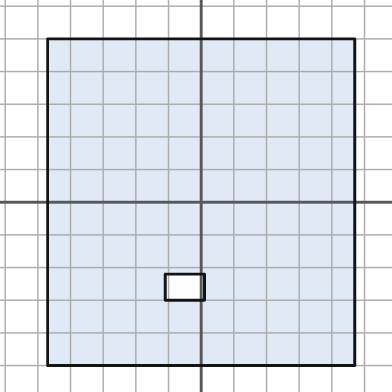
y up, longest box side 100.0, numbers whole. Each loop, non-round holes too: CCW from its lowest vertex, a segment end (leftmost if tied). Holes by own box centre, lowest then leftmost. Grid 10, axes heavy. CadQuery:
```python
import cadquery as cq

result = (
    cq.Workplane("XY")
    .moveTo(-47.0, -50.0)
    .lineTo(47.0, -50.0)
    .lineTo(47.0, 50.0)
    .lineTo(-47.0, 50.0)
    .close()
    .moveTo(-11.0, -30.0)
    .lineTo(1.0, -30.0)
    .lineTo(1.0, -22.0)
    .lineTo(-11.0, -22.0)
    .close()
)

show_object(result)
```